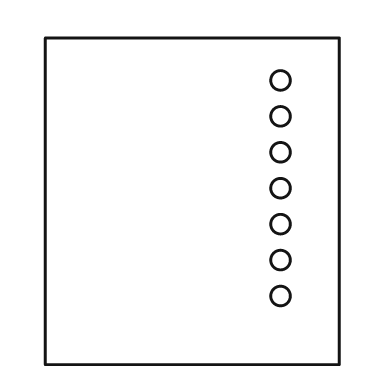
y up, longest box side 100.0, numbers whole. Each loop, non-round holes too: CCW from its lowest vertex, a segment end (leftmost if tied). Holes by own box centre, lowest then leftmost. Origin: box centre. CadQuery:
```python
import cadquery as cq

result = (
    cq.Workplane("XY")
    .moveTo(-45.0, -50.0)
    .lineTo(45.0, -50.0)
    .lineTo(45.0, 50.0)
    .lineTo(-45.0, 50.0)
    .close()
    .moveTo(27.0, -29.0)
    .circle(3.0)
    .moveTo(27.0, -18.0)
    .circle(3.0)
    .moveTo(27.0, -7.0)
    .circle(3.0)
    .moveTo(27.0, 4.0)
    .circle(3.0)
    .moveTo(27.0, 15.0)
    .circle(3.0)
    .moveTo(27.0, 26.0)
    .circle(3.0)
    .moveTo(27.0, 37.0)
    .circle(3.0)
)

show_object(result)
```